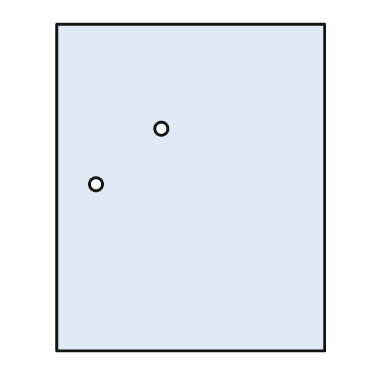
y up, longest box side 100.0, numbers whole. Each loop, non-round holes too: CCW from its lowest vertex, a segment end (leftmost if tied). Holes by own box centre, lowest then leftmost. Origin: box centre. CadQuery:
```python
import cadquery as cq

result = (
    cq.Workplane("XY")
    .moveTo(-41.0, -50.0)
    .lineTo(41.0, -50.0)
    .lineTo(41.0, 50.0)
    .lineTo(-41.0, 50.0)
    .close()
    .moveTo(-29.0, 1.0)
    .circle(2.0)
    .moveTo(-9.0, 18.0)
    .circle(2.0)
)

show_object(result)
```